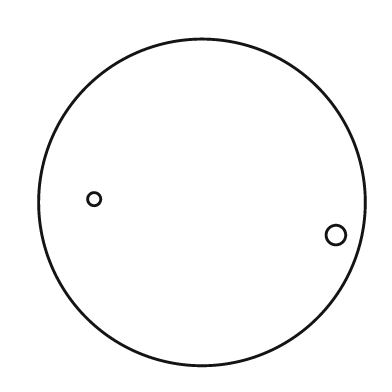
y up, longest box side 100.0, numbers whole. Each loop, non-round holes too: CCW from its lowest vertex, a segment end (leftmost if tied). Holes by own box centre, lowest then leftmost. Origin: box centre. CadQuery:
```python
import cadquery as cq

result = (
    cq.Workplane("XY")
    .moveTo(0.0, 0.0)
    .circle(50.0)
    .moveTo(41.0, -10.0)
    .circle(3.0)
    .moveTo(-33.0, 1.0)
    .circle(2.0)
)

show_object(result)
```